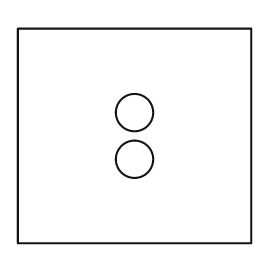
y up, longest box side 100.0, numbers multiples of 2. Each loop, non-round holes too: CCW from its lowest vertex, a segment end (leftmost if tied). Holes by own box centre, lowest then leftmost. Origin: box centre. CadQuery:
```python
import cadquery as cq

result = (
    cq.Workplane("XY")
    .moveTo(-50.0, -46.0)
    .lineTo(50.0, -46.0)
    .lineTo(50.0, 46.0)
    .lineTo(-50.0, 46.0)
    .close()
    .moveTo(0.0, -10.0)
    .circle(8.0)
    .moveTo(0.0, 10.0)
    .circle(8.0)
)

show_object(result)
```